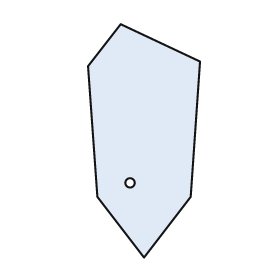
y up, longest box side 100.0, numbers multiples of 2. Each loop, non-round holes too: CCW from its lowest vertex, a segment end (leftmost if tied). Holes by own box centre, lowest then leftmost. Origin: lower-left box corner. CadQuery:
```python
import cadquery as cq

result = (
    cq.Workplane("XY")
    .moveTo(24.0, 0.0)
    .lineTo(44.0, 26.0)
    .lineTo(48.0, 84.0)
    .lineTo(14.0, 100.0)
    .lineTo(0.0, 82.0)
    .lineTo(4.0, 26.0)
    .close()
    .moveTo(18.0, 32.0)
    .circle(2.0)
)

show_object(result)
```